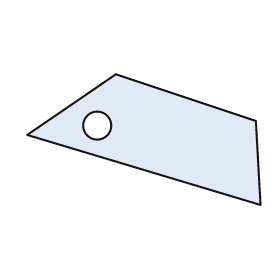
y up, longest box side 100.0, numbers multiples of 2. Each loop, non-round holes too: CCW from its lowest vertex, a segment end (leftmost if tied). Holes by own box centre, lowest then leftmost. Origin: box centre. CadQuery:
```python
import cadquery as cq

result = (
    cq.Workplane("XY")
    .moveTo(50.0, -28.0)
    .lineTo(48.0, 8.0)
    .lineTo(-12.0, 28.0)
    .lineTo(-50.0, 2.0)
    .close()
    .moveTo(-20.0, 6.0)
    .circle(6.0)
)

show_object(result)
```